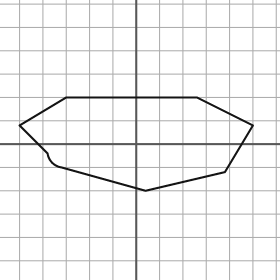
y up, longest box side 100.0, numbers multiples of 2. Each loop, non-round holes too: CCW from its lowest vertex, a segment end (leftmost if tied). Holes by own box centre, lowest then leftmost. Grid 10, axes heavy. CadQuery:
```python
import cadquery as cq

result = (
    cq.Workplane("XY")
    .moveTo(4.0, -20.0)
    .lineTo(38.0, -12.0)
    .lineTo(50.0, 8.0)
    .lineTo(26.0, 20.0)
    .lineTo(-30.0, 20.0)
    .lineTo(-50.0, 8.0)
    .lineTo(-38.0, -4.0)
    .threePointArc((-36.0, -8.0), (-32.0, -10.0))
    .close()
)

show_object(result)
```